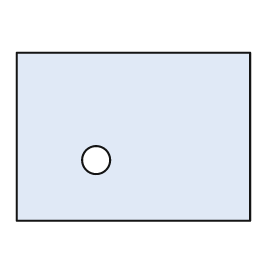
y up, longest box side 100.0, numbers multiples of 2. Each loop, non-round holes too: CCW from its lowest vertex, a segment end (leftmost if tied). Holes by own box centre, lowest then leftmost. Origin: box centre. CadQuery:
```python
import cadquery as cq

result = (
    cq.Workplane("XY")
    .moveTo(-50.0, -36.0)
    .lineTo(50.0, -36.0)
    .lineTo(50.0, 36.0)
    .lineTo(-50.0, 36.0)
    .close()
    .moveTo(-16.0, -10.0)
    .circle(6.0)
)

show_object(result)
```